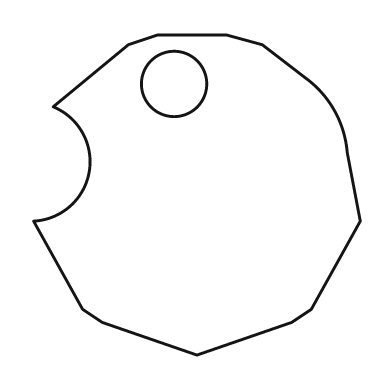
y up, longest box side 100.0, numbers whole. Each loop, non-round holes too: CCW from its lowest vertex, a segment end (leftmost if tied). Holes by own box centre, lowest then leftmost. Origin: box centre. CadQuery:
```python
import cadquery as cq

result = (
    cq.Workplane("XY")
    .moveTo(0.0, -49.0)
    .lineTo(29.0, -39.0)
    .lineTo(35.0, -35.0)
    .lineTo(50.0, -8.0)
    .lineTo(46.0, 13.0)
    .threePointArc((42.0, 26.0), (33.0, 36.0))
    .lineTo(20.0, 46.0)
    .lineTo(9.0, 49.0)
    .lineTo(-12.0, 49.0)
    .lineTo(-21.0, 46.0)
    .lineTo(-44.0, 27.0)
    .threePointArc((-33.0, 7.0), (-50.0, -8.0))
    .lineTo(-35.0, -35.0)
    .lineTo(-29.0, -39.0)
    .close()
    .moveTo(-7.0, 34.0)
    .circle(10.0)
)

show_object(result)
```